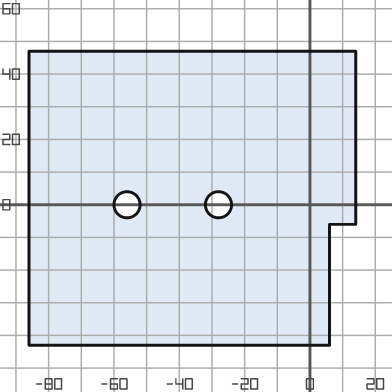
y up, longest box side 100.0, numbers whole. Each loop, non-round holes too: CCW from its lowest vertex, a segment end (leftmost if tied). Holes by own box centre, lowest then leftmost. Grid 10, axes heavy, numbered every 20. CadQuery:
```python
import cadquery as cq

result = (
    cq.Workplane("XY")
    .moveTo(-86.0, -43.0)
    .lineTo(6.0, -43.0)
    .lineTo(6.0, -6.0)
    .lineTo(14.0, -6.0)
    .lineTo(14.0, 47.0)
    .lineTo(-86.0, 47.0)
    .close()
    .moveTo(-56.0, 0.0)
    .circle(4.0)
    .moveTo(-28.0, 0.0)
    .circle(4.0)
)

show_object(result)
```